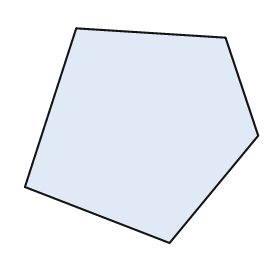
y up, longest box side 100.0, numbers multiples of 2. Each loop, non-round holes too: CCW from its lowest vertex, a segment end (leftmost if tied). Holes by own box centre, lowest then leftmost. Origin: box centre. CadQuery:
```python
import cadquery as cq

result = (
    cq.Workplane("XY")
    .moveTo(12.0, -46.0)
    .lineTo(50.0, 0.0)
    .lineTo(36.0, 42.0)
    .lineTo(-28.0, 46.0)
    .lineTo(-50.0, -22.0)
    .close()
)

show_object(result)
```